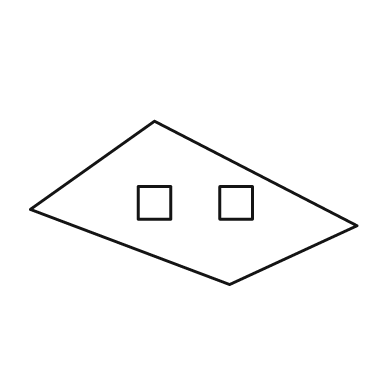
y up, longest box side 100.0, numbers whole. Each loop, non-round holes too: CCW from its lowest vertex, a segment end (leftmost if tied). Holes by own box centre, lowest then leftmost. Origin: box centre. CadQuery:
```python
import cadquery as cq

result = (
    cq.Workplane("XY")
    .moveTo(11.0, -25.0)
    .lineTo(50.0, -7.0)
    .lineTo(-12.0, 25.0)
    .lineTo(-50.0, -2.0)
    .close()
    .moveTo(-17.0, -5.0)
    .lineTo(-7.0, -5.0)
    .lineTo(-7.0, 5.0)
    .lineTo(-17.0, 5.0)
    .close()
    .moveTo(8.0, -5.0)
    .lineTo(18.0, -5.0)
    .lineTo(18.0, 5.0)
    .lineTo(8.0, 5.0)
    .close()
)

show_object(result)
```